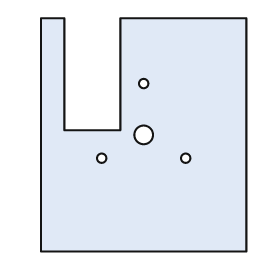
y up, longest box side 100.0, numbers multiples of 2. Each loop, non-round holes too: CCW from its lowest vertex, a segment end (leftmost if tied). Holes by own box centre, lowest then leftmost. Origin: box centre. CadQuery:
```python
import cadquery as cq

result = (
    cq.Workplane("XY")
    .moveTo(-44.0, -50.0)
    .lineTo(44.0, -50.0)
    .lineTo(44.0, 50.0)
    .lineTo(-10.0, 50.0)
    .lineTo(-10.0, 2.0)
    .lineTo(-34.0, 2.0)
    .lineTo(-34.0, 50.0)
    .lineTo(-44.0, 50.0)
    .close()
    .moveTo(-18.0, -10.0)
    .circle(2.0)
    .moveTo(18.0, -10.0)
    .circle(2.0)
    .moveTo(0.0, 0.0)
    .circle(4.0)
    .moveTo(0.0, 22.0)
    .circle(2.0)
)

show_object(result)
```